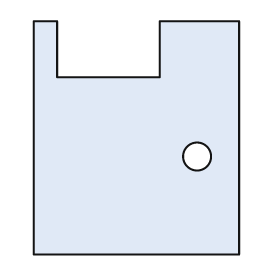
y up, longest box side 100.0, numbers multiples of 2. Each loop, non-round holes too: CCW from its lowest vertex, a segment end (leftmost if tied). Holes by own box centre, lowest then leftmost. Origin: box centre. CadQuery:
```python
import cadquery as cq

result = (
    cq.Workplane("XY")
    .moveTo(-44.0, -50.0)
    .lineTo(44.0, -50.0)
    .lineTo(44.0, 50.0)
    .lineTo(10.0, 50.0)
    .lineTo(10.0, 26.0)
    .lineTo(-34.0, 26.0)
    .lineTo(-34.0, 50.0)
    .lineTo(-44.0, 50.0)
    .close()
    .moveTo(26.0, -8.0)
    .circle(6.0)
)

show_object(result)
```